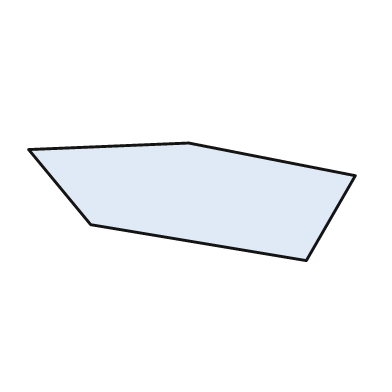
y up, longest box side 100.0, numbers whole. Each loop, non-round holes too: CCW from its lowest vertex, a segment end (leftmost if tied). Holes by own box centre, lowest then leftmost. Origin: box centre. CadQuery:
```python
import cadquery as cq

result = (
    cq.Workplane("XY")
    .moveTo(35.0, -18.0)
    .lineTo(50.0, 8.0)
    .lineTo(-1.0, 18.0)
    .lineTo(-50.0, 16.0)
    .lineTo(-31.0, -7.0)
    .close()
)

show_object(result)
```